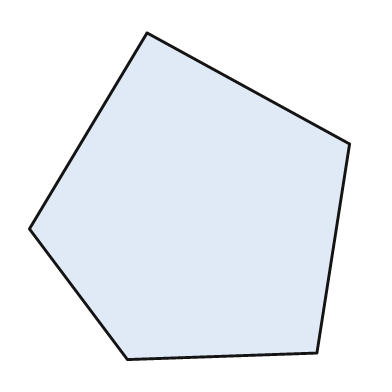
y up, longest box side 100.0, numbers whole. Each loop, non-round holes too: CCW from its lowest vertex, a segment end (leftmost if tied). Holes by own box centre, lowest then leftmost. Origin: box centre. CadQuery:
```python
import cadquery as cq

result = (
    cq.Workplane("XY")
    .moveTo(-19.0, -50.0)
    .lineTo(39.0, -48.0)
    .lineTo(49.0, 16.0)
    .lineTo(-13.0, 50.0)
    .lineTo(-49.0, -10.0)
    .close()
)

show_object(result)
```